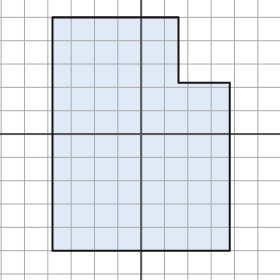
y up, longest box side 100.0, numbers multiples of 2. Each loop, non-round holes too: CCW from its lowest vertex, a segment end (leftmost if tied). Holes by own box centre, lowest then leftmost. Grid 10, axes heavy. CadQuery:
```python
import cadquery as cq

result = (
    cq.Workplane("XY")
    .moveTo(-38.0, -50.0)
    .lineTo(38.0, -50.0)
    .lineTo(38.0, 22.0)
    .lineTo(16.0, 22.0)
    .lineTo(16.0, 50.0)
    .lineTo(-38.0, 50.0)
    .close()
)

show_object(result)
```